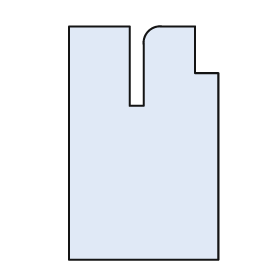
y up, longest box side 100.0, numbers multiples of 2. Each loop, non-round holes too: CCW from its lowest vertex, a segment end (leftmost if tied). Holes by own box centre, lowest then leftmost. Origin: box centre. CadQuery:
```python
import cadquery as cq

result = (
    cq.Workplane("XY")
    .moveTo(-32.0, -50.0)
    .lineTo(32.0, -50.0)
    .lineTo(32.0, 30.0)
    .lineTo(22.0, 30.0)
    .lineTo(22.0, 50.0)
    .lineTo(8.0, 50.0)
    .threePointArc((2.0, 48.0), (0.0, 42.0))
    .lineTo(0.0, 16.0)
    .lineTo(-6.0, 16.0)
    .lineTo(-6.0, 50.0)
    .lineTo(-32.0, 50.0)
    .close()
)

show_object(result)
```